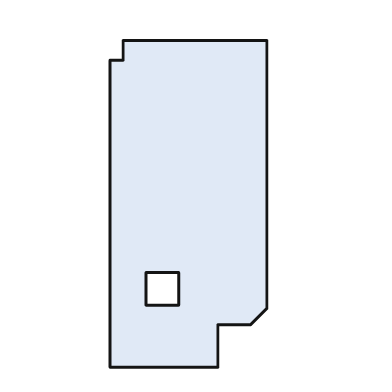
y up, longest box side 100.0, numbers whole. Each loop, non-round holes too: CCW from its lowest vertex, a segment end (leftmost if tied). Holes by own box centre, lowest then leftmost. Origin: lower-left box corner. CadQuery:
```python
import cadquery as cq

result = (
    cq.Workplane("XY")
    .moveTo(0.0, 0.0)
    .lineTo(33.0, 0.0)
    .lineTo(33.0, 13.0)
    .lineTo(43.0, 13.0)
    .lineTo(48.0, 18.0)
    .lineTo(48.0, 100.0)
    .lineTo(4.0, 100.0)
    .lineTo(4.0, 94.0)
    .lineTo(0.0, 94.0)
    .close()
    .moveTo(11.0, 19.0)
    .lineTo(21.0, 19.0)
    .lineTo(21.0, 29.0)
    .lineTo(11.0, 29.0)
    .close()
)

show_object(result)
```